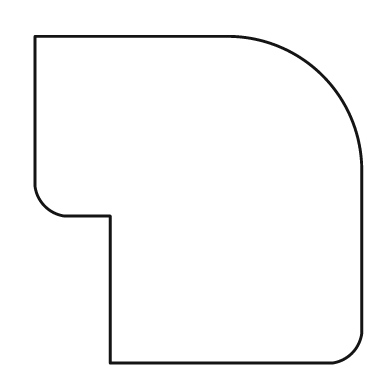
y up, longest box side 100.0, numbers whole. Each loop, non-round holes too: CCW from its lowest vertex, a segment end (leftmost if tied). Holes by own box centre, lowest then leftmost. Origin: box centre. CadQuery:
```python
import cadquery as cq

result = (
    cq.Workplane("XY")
    .moveTo(-27.0, -50.0)
    .lineTo(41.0, -50.0)
    .threePointArc((47.0, -47.0), (50.0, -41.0))
    .lineTo(50.0, 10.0)
    .threePointArc((38.0, 38.0), (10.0, 50.0))
    .lineTo(-50.0, 50.0)
    .lineTo(-50.0, 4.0)
    .threePointArc((-47.0, -2.0), (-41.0, -5.0))
    .lineTo(-27.0, -5.0)
    .close()
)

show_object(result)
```